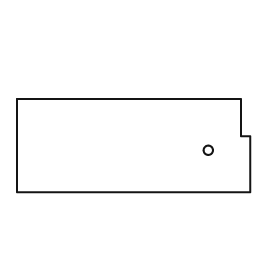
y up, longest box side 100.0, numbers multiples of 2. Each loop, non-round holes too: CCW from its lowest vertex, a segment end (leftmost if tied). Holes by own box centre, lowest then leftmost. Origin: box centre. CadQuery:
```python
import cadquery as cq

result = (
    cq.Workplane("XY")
    .moveTo(-50.0, -20.0)
    .lineTo(50.0, -20.0)
    .lineTo(50.0, 4.0)
    .lineTo(46.0, 4.0)
    .lineTo(46.0, 20.0)
    .lineTo(-50.0, 20.0)
    .close()
    .moveTo(32.0, -2.0)
    .circle(2.0)
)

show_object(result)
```